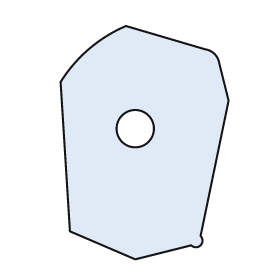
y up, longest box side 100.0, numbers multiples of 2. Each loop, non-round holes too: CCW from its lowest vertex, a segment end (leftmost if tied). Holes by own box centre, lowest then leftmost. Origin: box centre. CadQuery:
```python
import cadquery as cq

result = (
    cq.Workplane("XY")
    .moveTo(-4.0, -50.0)
    .lineTo(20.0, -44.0)
    .threePointArc((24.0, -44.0), (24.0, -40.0))
    .lineTo(36.0, 18.0)
    .lineTo(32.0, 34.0)
    .threePointArc((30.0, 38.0), (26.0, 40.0))
    .lineTo(-8.0, 50.0)
    .threePointArc((-24.0, 40.0), (-36.0, 26.0))
    .lineTo(-32.0, -38.0)
    .close()
    .moveTo(-4.0, 6.0)
    .circle(8.0)
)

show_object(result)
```